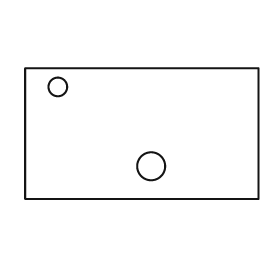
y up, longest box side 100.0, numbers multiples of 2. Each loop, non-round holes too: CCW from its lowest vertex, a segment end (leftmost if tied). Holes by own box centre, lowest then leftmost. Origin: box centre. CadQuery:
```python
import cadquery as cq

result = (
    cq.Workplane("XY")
    .moveTo(-50.0, -28.0)
    .lineTo(50.0, -28.0)
    .lineTo(50.0, 28.0)
    .lineTo(-50.0, 28.0)
    .close()
    .moveTo(4.0, -14.0)
    .circle(6.0)
    .moveTo(-36.0, 20.0)
    .circle(4.0)
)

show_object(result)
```